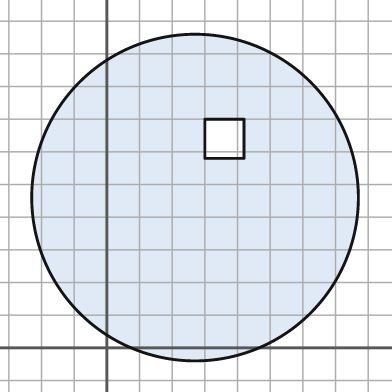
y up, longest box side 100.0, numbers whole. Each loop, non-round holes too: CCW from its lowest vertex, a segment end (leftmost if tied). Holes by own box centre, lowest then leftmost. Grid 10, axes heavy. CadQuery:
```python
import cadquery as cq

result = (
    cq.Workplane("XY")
    .moveTo(27.0, 46.0)
    .circle(50.0)
    .moveTo(30.0, 58.0)
    .lineTo(42.0, 58.0)
    .lineTo(42.0, 70.0)
    .lineTo(30.0, 70.0)
    .close()
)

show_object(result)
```